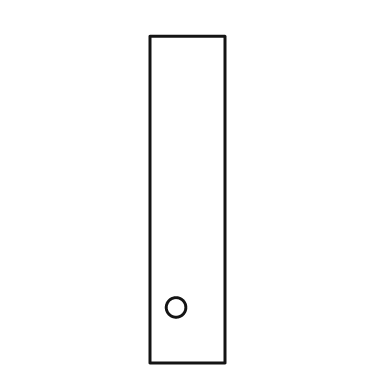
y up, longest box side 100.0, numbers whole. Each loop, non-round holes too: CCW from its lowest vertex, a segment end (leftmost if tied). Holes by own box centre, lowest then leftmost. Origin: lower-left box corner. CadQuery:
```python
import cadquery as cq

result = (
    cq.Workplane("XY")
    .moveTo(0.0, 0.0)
    .lineTo(23.0, 0.0)
    .lineTo(23.0, 100.0)
    .lineTo(0.0, 100.0)
    .close()
    .moveTo(8.0, 17.0)
    .circle(3.0)
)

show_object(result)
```